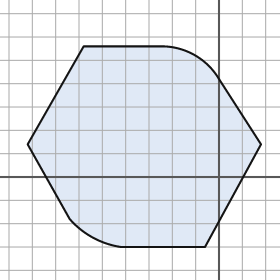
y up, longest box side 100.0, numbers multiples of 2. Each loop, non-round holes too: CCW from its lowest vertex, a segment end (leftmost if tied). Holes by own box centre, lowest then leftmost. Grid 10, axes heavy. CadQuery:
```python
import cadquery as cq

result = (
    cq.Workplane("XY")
    .moveTo(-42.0, -30.0)
    .lineTo(-6.0, -30.0)
    .lineTo(18.0, 14.0)
    .lineTo(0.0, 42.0)
    .threePointArc((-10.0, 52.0), (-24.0, 56.0))
    .lineTo(-58.0, 56.0)
    .lineTo(-82.0, 14.0)
    .lineTo(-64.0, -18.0)
    .threePointArc((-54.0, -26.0), (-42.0, -30.0))
    .close()
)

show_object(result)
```